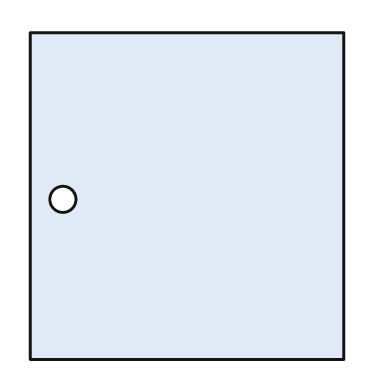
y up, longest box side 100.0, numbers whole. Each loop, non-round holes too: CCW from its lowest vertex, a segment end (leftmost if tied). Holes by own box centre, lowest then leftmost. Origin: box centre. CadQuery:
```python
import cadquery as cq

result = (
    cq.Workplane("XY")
    .moveTo(-48.0, -50.0)
    .lineTo(48.0, -50.0)
    .lineTo(48.0, 50.0)
    .lineTo(-48.0, 50.0)
    .close()
    .moveTo(-38.0, -1.0)
    .circle(4.0)
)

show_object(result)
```